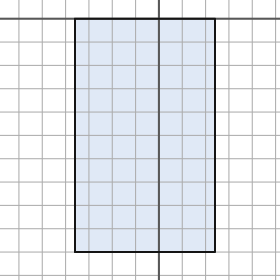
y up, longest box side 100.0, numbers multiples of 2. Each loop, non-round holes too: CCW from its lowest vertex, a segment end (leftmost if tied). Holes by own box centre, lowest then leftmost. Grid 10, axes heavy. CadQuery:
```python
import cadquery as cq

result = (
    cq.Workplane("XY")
    .moveTo(-36.0, -100.0)
    .lineTo(24.0, -100.0)
    .lineTo(24.0, 0.0)
    .lineTo(-36.0, 0.0)
    .close()
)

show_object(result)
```